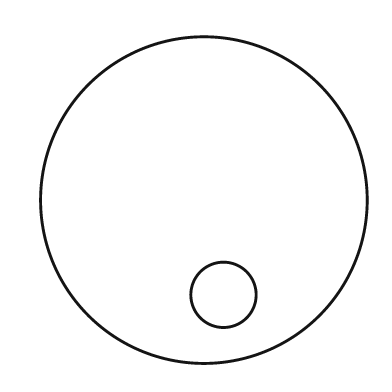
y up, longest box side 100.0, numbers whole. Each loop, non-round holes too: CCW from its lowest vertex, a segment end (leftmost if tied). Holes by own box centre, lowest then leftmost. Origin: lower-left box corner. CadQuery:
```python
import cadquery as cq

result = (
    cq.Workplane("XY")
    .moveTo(50.0, 50.0)
    .circle(50.0)
    .moveTo(56.0, 21.0)
    .circle(10.0)
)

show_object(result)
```